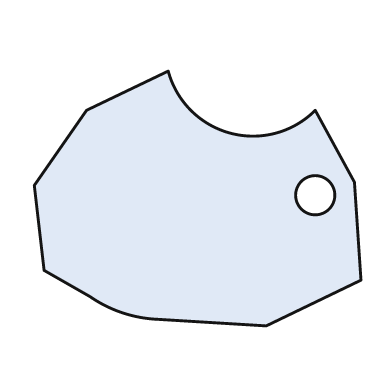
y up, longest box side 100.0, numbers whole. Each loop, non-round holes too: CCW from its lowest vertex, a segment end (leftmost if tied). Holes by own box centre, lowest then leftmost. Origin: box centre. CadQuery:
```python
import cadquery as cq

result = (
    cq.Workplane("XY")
    .moveTo(21.0, -39.0)
    .lineTo(50.0, -25.0)
    .lineTo(48.0, 5.0)
    .lineTo(36.0, 27.0)
    .threePointArc((10.0, 20.0), (-9.0, 39.0))
    .lineTo(-34.0, 27.0)
    .lineTo(-50.0, 4.0)
    .lineTo(-47.0, -22.0)
    .lineTo(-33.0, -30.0)
    .threePointArc((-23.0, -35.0), (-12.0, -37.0))
    .close()
    .moveTo(36.0, 1.0)
    .circle(6.0)
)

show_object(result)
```